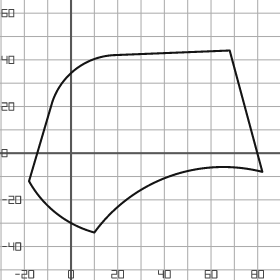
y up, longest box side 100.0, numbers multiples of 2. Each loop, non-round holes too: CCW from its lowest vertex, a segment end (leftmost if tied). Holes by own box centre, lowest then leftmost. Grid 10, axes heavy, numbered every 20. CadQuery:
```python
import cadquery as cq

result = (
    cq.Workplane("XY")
    .moveTo(10.0, -34.0)
    .threePointArc((42.0, -10.0), (82.0, -8.0))
    .lineTo(68.0, 44.0)
    .lineTo(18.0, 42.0)
    .threePointArc((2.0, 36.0), (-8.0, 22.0))
    .lineTo(-18.0, -12.0)
    .threePointArc((-6.0, -26.0), (10.0, -34.0))
    .close()
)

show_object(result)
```